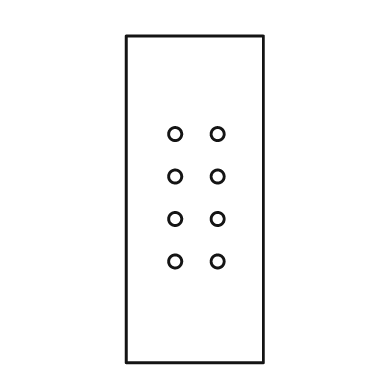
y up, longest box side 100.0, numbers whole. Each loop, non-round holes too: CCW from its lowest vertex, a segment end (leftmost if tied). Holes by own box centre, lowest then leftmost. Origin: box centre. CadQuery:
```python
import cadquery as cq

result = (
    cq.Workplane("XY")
    .moveTo(-21.0, -50.0)
    .lineTo(21.0, -50.0)
    .lineTo(21.0, 50.0)
    .lineTo(-21.0, 50.0)
    .close()
    .moveTo(-6.0, -19.0)
    .circle(2.0)
    .moveTo(7.0, -19.0)
    .circle(2.0)
    .moveTo(-6.0, -6.0)
    .circle(2.0)
    .moveTo(7.0, -6.0)
    .circle(2.0)
    .moveTo(-6.0, 7.0)
    .circle(2.0)
    .moveTo(7.0, 7.0)
    .circle(2.0)
    .moveTo(-6.0, 20.0)
    .circle(2.0)
    .moveTo(7.0, 20.0)
    .circle(2.0)
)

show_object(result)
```